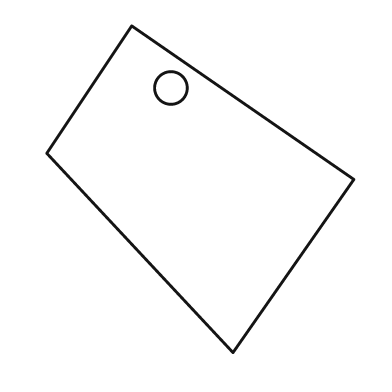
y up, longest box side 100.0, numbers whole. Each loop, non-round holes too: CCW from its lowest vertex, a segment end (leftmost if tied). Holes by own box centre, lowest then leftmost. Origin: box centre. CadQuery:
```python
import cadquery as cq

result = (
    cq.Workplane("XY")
    .moveTo(10.0, -50.0)
    .lineTo(47.0, 3.0)
    .lineTo(-21.0, 50.0)
    .lineTo(-47.0, 11.0)
    .close()
    .moveTo(-9.0, 31.0)
    .circle(5.0)
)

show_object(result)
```